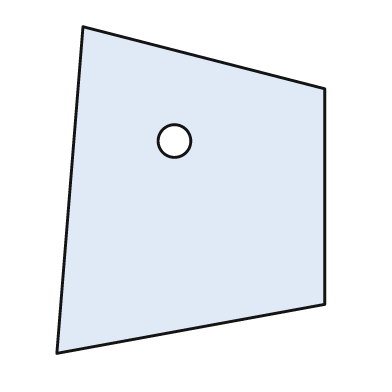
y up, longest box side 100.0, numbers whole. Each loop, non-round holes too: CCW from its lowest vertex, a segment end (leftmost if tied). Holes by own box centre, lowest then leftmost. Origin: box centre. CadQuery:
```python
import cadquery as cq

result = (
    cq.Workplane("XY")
    .moveTo(-41.0, -50.0)
    .lineTo(41.0, -35.0)
    .lineTo(41.0, 31.0)
    .lineTo(-33.0, 50.0)
    .close()
    .moveTo(-5.0, 15.0)
    .circle(5.0)
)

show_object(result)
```